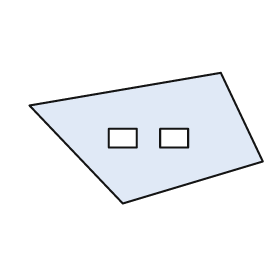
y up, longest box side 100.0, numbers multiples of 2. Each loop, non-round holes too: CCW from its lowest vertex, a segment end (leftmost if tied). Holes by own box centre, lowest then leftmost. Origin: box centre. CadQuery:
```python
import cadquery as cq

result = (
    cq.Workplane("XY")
    .moveTo(-10.0, -28.0)
    .lineTo(50.0, -10.0)
    .lineTo(32.0, 28.0)
    .lineTo(-50.0, 14.0)
    .close()
    .moveTo(-16.0, -4.0)
    .lineTo(-4.0, -4.0)
    .lineTo(-4.0, 4.0)
    .lineTo(-16.0, 4.0)
    .close()
    .moveTo(6.0, -4.0)
    .lineTo(18.0, -4.0)
    .lineTo(18.0, 4.0)
    .lineTo(6.0, 4.0)
    .close()
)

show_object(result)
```